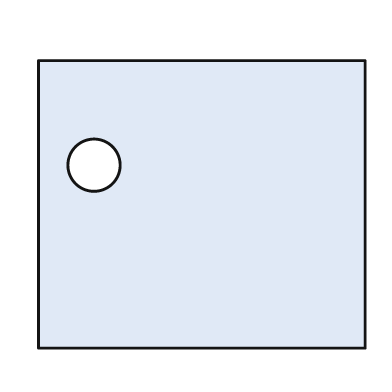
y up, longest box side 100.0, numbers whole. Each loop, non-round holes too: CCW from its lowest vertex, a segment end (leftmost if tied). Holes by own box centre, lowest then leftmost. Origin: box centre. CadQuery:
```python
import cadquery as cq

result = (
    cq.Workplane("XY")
    .moveTo(-50.0, -44.0)
    .lineTo(50.0, -44.0)
    .lineTo(50.0, 44.0)
    .lineTo(-50.0, 44.0)
    .close()
    .moveTo(-33.0, 12.0)
    .circle(8.0)
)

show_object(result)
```